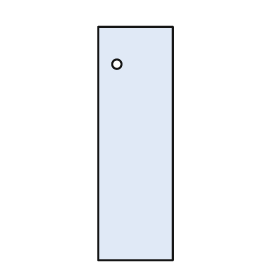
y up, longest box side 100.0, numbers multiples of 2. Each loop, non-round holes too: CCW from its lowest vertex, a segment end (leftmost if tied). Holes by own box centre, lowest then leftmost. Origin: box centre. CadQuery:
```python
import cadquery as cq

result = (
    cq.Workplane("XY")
    .moveTo(-16.0, -50.0)
    .lineTo(16.0, -50.0)
    .lineTo(16.0, 50.0)
    .lineTo(-16.0, 50.0)
    .close()
    .moveTo(-8.0, 34.0)
    .circle(2.0)
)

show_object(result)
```